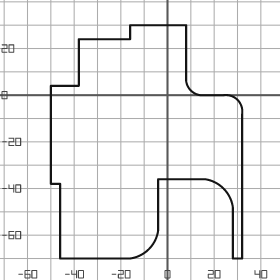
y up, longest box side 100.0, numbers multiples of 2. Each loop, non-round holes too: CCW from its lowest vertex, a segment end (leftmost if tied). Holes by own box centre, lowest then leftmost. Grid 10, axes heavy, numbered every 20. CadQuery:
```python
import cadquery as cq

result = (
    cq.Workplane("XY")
    .moveTo(-46.0, -70.0)
    .lineTo(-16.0, -70.0)
    .threePointArc((-8.0, -66.0), (-4.0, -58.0))
    .lineTo(-4.0, -36.0)
    .lineTo(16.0, -36.0)
    .threePointArc((24.0, -40.0), (28.0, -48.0))
    .lineTo(28.0, -70.0)
    .lineTo(32.0, -70.0)
    .lineTo(32.0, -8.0)
    .threePointArc((30.0, -2.0), (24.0, 0.0))
    .lineTo(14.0, 0.0)
    .threePointArc((10.0, 2.0), (8.0, 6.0))
    .lineTo(8.0, 30.0)
    .lineTo(-16.0, 30.0)
    .lineTo(-16.0, 24.0)
    .lineTo(-38.0, 24.0)
    .lineTo(-38.0, 4.0)
    .lineTo(-50.0, 4.0)
    .lineTo(-50.0, -38.0)
    .lineTo(-46.0, -38.0)
    .close()
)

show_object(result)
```